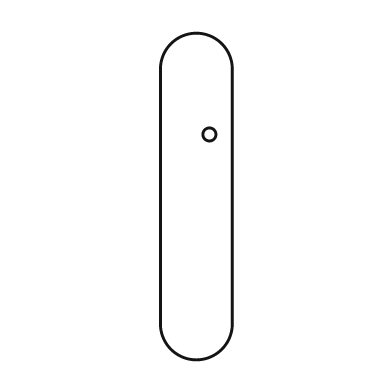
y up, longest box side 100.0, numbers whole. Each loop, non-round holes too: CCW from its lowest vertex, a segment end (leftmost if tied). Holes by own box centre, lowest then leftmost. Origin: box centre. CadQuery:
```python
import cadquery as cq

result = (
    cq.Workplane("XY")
    .moveTo(-11.0, -39.0)
    .threePointArc((0.0, -50.0), (11.0, -39.0))
    .lineTo(11.0, 39.0)
    .threePointArc((0.0, 50.0), (-11.0, 39.0))
    .close()
    .moveTo(4.0, 19.0)
    .circle(2.0)
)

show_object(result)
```